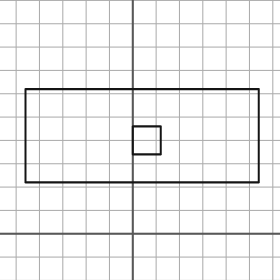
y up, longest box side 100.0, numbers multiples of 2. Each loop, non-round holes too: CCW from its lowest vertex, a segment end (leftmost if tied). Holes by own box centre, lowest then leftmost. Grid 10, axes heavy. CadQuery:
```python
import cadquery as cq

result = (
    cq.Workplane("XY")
    .moveTo(-46.0, 22.0)
    .lineTo(54.0, 22.0)
    .lineTo(54.0, 62.0)
    .lineTo(-46.0, 62.0)
    .close()
    .moveTo(0.0, 34.0)
    .lineTo(12.0, 34.0)
    .lineTo(12.0, 46.0)
    .lineTo(0.0, 46.0)
    .close()
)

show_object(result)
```